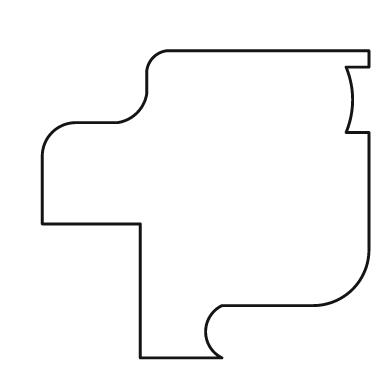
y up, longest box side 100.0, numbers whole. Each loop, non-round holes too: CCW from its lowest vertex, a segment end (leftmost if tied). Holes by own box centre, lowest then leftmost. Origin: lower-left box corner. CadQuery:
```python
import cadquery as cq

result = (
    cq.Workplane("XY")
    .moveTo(30.0, 0.0)
    .lineTo(55.0, 0.0)
    .threePointArc((50.0, 8.0), (55.0, 16.0))
    .lineTo(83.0, 16.0)
    .threePointArc((95.0, 21.0), (100.0, 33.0))
    .lineTo(100.0, 69.0)
    .lineTo(93.0, 69.0)
    .threePointArc((95.0, 79.0), (93.0, 89.0))
    .lineTo(100.0, 89.0)
    .lineTo(100.0, 94.0)
    .lineTo(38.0, 94.0)
    .threePointArc((34.0, 92.0), (32.0, 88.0))
    .lineTo(32.0, 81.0)
    .threePointArc((29.0, 75.0), (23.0, 72.0))
    .lineTo(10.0, 72.0)
    .threePointArc((3.0, 69.0), (0.0, 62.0))
    .lineTo(0.0, 41.0)
    .lineTo(30.0, 41.0)
    .close()
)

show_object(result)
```